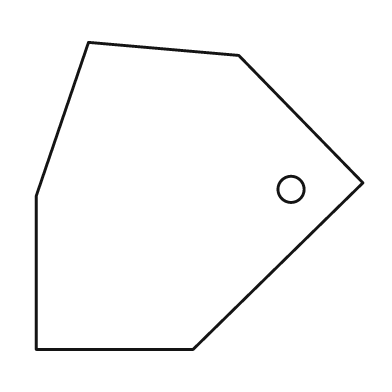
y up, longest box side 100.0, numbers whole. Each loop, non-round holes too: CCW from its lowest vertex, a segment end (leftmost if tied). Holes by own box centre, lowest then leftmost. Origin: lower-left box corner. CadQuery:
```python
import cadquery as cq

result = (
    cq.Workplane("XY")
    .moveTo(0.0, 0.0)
    .lineTo(48.0, 0.0)
    .lineTo(100.0, 51.0)
    .lineTo(62.0, 90.0)
    .lineTo(16.0, 94.0)
    .lineTo(0.0, 47.0)
    .close()
    .moveTo(78.0, 49.0)
    .circle(4.0)
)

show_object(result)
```